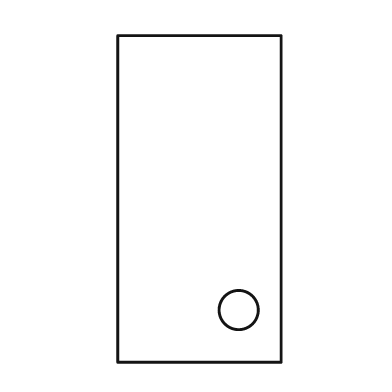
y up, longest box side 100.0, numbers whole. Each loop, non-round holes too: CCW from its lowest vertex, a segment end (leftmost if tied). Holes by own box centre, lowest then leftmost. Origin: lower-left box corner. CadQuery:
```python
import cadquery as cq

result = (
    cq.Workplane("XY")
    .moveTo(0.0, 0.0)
    .lineTo(50.0, 0.0)
    .lineTo(50.0, 100.0)
    .lineTo(0.0, 100.0)
    .close()
    .moveTo(37.0, 16.0)
    .circle(6.0)
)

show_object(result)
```